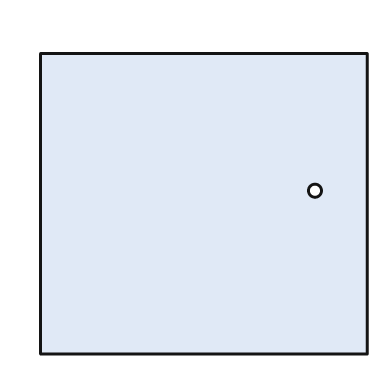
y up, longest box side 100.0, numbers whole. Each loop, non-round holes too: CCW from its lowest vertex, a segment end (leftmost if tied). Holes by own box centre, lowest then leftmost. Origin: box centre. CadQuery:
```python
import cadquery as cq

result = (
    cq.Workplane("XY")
    .moveTo(-50.0, -46.0)
    .lineTo(50.0, -46.0)
    .lineTo(50.0, 46.0)
    .lineTo(-50.0, 46.0)
    .close()
    .moveTo(34.0, 4.0)
    .circle(2.0)
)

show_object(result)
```